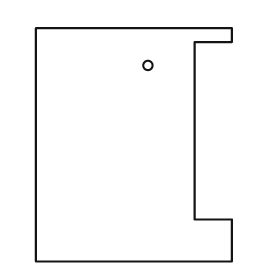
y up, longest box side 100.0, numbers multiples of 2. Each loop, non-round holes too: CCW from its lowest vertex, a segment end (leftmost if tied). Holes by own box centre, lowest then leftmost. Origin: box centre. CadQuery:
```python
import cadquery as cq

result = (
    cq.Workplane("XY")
    .moveTo(-42.0, -50.0)
    .lineTo(42.0, -50.0)
    .lineTo(42.0, -32.0)
    .lineTo(26.0, -32.0)
    .lineTo(26.0, 44.0)
    .lineTo(42.0, 44.0)
    .lineTo(42.0, 50.0)
    .lineTo(-42.0, 50.0)
    .close()
    .moveTo(6.0, 34.0)
    .circle(2.0)
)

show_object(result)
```